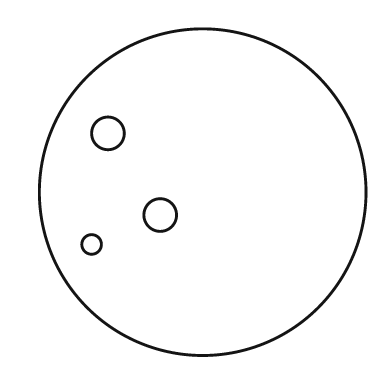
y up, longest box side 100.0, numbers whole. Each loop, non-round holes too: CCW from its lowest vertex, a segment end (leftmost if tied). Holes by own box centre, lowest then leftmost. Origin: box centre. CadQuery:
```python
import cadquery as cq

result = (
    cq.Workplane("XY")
    .moveTo(0.0, 0.0)
    .circle(50.0)
    .moveTo(-34.0, -16.0)
    .circle(3.0)
    .moveTo(-13.0, -7.0)
    .circle(5.0)
    .moveTo(-29.0, 18.0)
    .circle(5.0)
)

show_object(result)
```